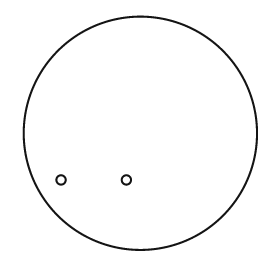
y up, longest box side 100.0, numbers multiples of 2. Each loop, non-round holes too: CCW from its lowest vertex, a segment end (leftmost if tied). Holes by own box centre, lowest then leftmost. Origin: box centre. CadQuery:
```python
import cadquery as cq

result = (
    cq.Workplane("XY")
    .moveTo(0.0, 0.0)
    .circle(50.0)
    .moveTo(-34.0, -20.0)
    .circle(2.0)
    .moveTo(-6.0, -20.0)
    .circle(2.0)
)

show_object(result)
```